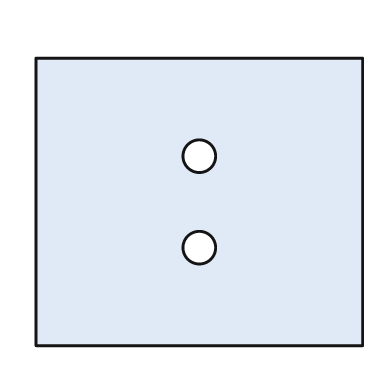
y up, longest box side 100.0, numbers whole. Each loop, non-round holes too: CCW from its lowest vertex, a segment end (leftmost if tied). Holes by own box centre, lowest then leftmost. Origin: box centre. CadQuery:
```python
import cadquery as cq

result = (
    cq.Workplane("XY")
    .moveTo(-50.0, -44.0)
    .lineTo(50.0, -44.0)
    .lineTo(50.0, 44.0)
    .lineTo(-50.0, 44.0)
    .close()
    .moveTo(0.0, -14.0)
    .circle(5.0)
    .moveTo(0.0, 14.0)
    .circle(5.0)
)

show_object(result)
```